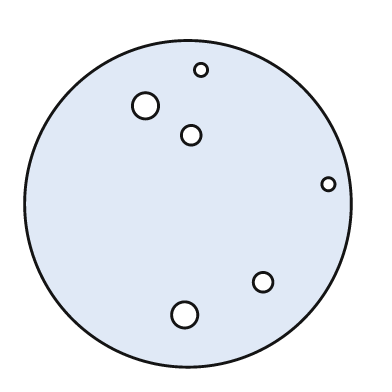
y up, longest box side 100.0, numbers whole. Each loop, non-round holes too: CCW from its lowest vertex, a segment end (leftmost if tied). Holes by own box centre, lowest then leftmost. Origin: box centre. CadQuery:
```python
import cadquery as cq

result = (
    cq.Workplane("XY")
    .moveTo(0.0, 0.0)
    .circle(50.0)
    .moveTo(-1.0, -34.0)
    .circle(4.0)
    .moveTo(23.0, -24.0)
    .circle(3.0)
    .moveTo(43.0, 6.0)
    .circle(2.0)
    .moveTo(1.0, 21.0)
    .circle(3.0)
    .moveTo(-13.0, 30.0)
    .circle(4.0)
    .moveTo(4.0, 41.0)
    .circle(2.0)
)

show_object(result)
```